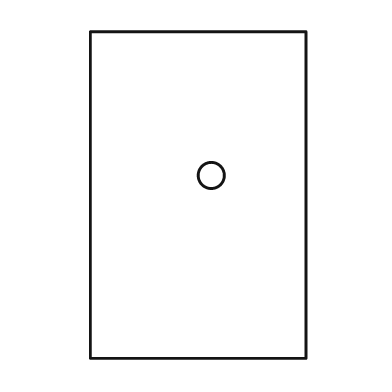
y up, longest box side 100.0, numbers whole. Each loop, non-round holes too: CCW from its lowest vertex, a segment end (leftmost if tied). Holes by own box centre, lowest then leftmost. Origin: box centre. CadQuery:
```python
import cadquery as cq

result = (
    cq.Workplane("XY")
    .moveTo(-33.0, -50.0)
    .lineTo(33.0, -50.0)
    .lineTo(33.0, 50.0)
    .lineTo(-33.0, 50.0)
    .close()
    .moveTo(4.0, 6.0)
    .circle(4.0)
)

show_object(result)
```